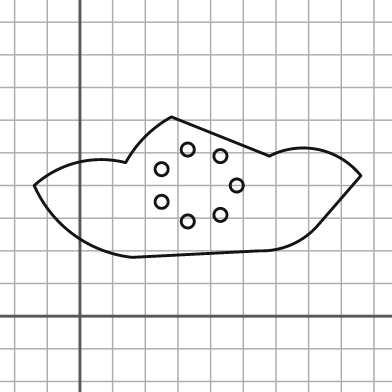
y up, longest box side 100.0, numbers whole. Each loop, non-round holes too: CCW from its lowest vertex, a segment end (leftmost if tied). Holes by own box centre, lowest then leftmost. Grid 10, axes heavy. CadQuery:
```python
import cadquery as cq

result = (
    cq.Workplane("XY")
    .moveTo(16.0, 18.0)
    .lineTo(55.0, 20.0)
    .threePointArc((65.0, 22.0), (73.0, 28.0))
    .lineTo(86.0, 43.0)
    .threePointArc((73.0, 51.0), (58.0, 49.0))
    .lineTo(28.0, 61.0)
    .threePointArc((20.0, 55.0), (14.0, 47.0))
    .threePointArc((-1.0, 47.0), (-14.0, 40.0))
    .threePointArc((-2.0, 25.0), (16.0, 18.0))
    .close()
    .moveTo(33.0, 29.0)
    .circle(2.0)
    .moveTo(43.0, 31.0)
    .circle(2.0)
    .moveTo(25.0, 35.0)
    .circle(2.0)
    .moveTo(48.0, 40.0)
    .circle(2.0)
    .moveTo(25.0, 45.0)
    .circle(2.0)
    .moveTo(43.0, 49.0)
    .circle(2.0)
    .moveTo(33.0, 51.0)
    .circle(2.0)
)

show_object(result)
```